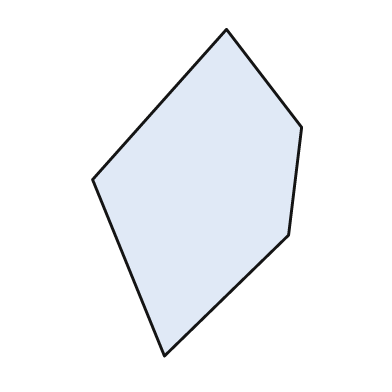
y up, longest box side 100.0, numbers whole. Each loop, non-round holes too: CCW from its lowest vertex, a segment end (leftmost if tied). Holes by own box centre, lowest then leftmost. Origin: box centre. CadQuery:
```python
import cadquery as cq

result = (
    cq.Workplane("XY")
    .moveTo(-10.0, -50.0)
    .lineTo(28.0, -13.0)
    .lineTo(32.0, 20.0)
    .lineTo(9.0, 50.0)
    .lineTo(-32.0, 4.0)
    .close()
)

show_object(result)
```